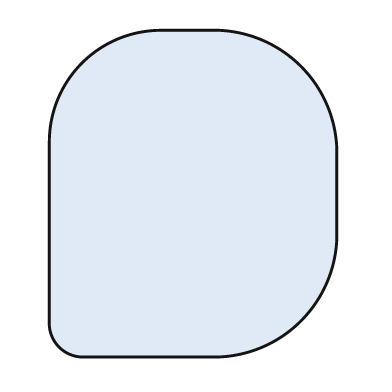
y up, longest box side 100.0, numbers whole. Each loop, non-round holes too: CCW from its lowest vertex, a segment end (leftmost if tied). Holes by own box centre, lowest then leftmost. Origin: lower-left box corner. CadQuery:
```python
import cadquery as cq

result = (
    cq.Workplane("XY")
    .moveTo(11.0, 0.0)
    .lineTo(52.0, 0.0)
    .threePointArc((77.0, 11.0), (88.0, 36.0))
    .lineTo(88.0, 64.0)
    .threePointArc((77.0, 89.0), (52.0, 100.0))
    .lineTo(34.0, 100.0)
    .threePointArc((10.0, 90.0), (0.0, 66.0))
    .lineTo(0.0, 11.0)
    .threePointArc((3.0, 3.0), (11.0, 0.0))
    .close()
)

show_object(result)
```